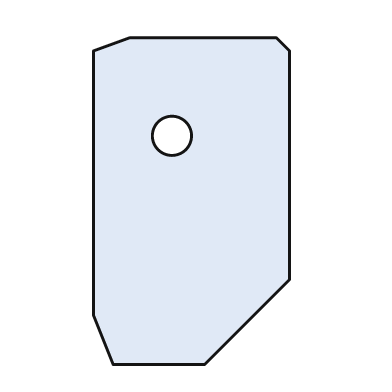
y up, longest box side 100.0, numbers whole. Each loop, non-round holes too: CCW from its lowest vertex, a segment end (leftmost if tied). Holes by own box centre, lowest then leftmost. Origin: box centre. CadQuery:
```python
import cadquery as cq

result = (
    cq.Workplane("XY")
    .moveTo(-24.0, -50.0)
    .lineTo(4.0, -50.0)
    .lineTo(30.0, -24.0)
    .lineTo(30.0, 46.0)
    .lineTo(26.0, 50.0)
    .lineTo(-19.0, 50.0)
    .lineTo(-30.0, 46.0)
    .lineTo(-30.0, -35.0)
    .close()
    .moveTo(-6.0, 20.0)
    .circle(6.0)
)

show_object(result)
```